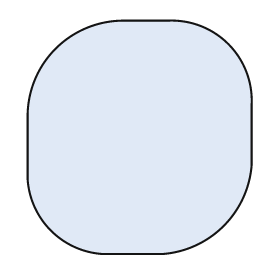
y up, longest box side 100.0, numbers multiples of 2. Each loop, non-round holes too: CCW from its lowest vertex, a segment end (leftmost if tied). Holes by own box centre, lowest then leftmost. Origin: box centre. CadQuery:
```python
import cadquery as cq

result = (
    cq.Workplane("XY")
    .moveTo(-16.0, -50.0)
    .lineTo(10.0, -50.0)
    .threePointArc((36.0, -38.0), (48.0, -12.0))
    .lineTo(48.0, 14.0)
    .threePointArc((38.0, 40.0), (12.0, 50.0))
    .lineTo(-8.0, 50.0)
    .threePointArc((-36.0, 38.0), (-48.0, 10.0))
    .lineTo(-48.0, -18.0)
    .threePointArc((-38.0, -40.0), (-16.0, -50.0))
    .close()
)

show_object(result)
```